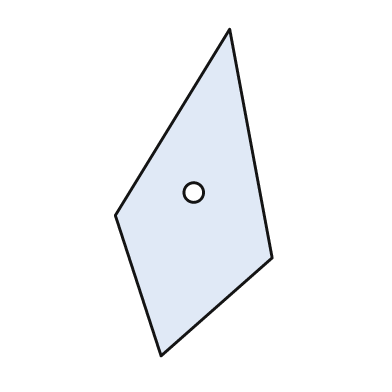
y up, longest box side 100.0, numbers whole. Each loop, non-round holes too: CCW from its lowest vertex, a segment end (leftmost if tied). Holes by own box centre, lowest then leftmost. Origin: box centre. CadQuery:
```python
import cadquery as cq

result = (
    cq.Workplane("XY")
    .moveTo(-10.0, -50.0)
    .lineTo(24.0, -20.0)
    .lineTo(11.0, 50.0)
    .lineTo(-24.0, -7.0)
    .close()
    .moveTo(0.0, 0.0)
    .circle(3.0)
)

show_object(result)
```